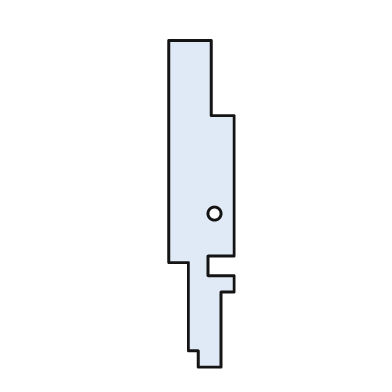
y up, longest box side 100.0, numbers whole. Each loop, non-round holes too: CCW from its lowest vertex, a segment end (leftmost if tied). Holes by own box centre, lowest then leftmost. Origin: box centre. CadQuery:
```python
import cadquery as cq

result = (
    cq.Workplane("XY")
    .moveTo(-1.0, -50.0)
    .lineTo(6.0, -50.0)
    .lineTo(6.0, -27.0)
    .lineTo(10.0, -27.0)
    .lineTo(10.0, -22.0)
    .lineTo(2.0, -22.0)
    .lineTo(2.0, -16.0)
    .lineTo(10.0, -16.0)
    .lineTo(10.0, 27.0)
    .lineTo(3.0, 27.0)
    .lineTo(3.0, 50.0)
    .lineTo(-10.0, 50.0)
    .lineTo(-10.0, -18.0)
    .lineTo(-4.0, -18.0)
    .lineTo(-4.0, -45.0)
    .lineTo(-1.0, -45.0)
    .close()
    .moveTo(4.0, -3.0)
    .circle(2.0)
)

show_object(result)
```